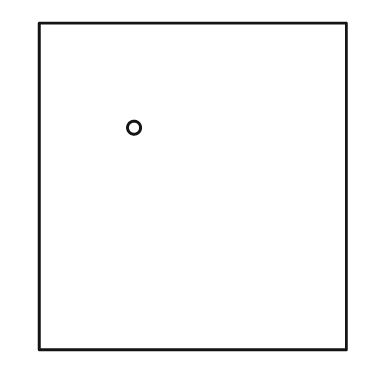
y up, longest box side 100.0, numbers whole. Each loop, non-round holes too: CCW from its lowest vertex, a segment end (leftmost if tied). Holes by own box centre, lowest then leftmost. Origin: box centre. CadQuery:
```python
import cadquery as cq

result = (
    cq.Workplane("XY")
    .moveTo(-47.0, -50.0)
    .lineTo(47.0, -50.0)
    .lineTo(47.0, 50.0)
    .lineTo(-47.0, 50.0)
    .close()
    .moveTo(-18.0, 18.0)
    .circle(2.0)
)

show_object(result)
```